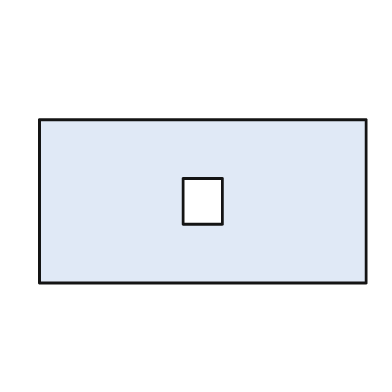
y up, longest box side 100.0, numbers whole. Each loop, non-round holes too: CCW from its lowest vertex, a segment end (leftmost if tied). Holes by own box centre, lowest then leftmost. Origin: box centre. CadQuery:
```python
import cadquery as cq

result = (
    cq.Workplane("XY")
    .moveTo(-50.0, -25.0)
    .lineTo(50.0, -25.0)
    .lineTo(50.0, 25.0)
    .lineTo(-50.0, 25.0)
    .close()
    .moveTo(-6.0, -7.0)
    .lineTo(6.0, -7.0)
    .lineTo(6.0, 7.0)
    .lineTo(-6.0, 7.0)
    .close()
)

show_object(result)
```